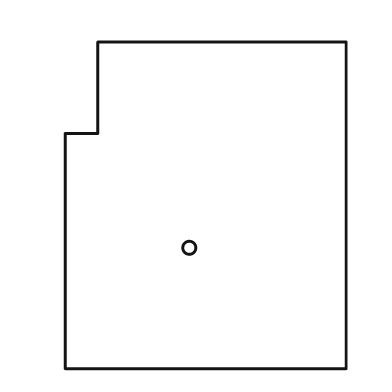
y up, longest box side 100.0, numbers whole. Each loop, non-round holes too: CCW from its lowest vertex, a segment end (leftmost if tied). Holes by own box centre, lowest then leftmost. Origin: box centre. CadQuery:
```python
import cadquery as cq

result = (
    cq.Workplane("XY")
    .moveTo(-43.0, -50.0)
    .lineTo(43.0, -50.0)
    .lineTo(43.0, 50.0)
    .lineTo(-33.0, 50.0)
    .lineTo(-33.0, 22.0)
    .lineTo(-43.0, 22.0)
    .close()
    .moveTo(-5.0, -13.0)
    .circle(2.0)
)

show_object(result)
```